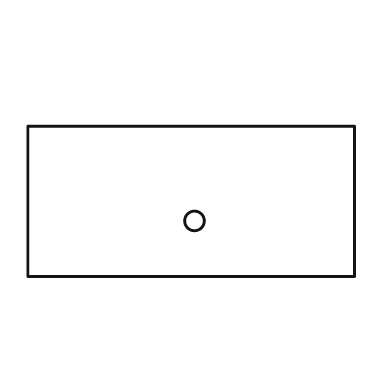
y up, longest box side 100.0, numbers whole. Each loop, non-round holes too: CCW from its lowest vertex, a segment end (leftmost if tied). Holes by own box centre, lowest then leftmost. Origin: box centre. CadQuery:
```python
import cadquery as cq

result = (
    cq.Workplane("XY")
    .moveTo(-50.0, -23.0)
    .lineTo(50.0, -23.0)
    .lineTo(50.0, 23.0)
    .lineTo(-50.0, 23.0)
    .close()
    .moveTo(1.0, -6.0)
    .circle(3.0)
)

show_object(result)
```